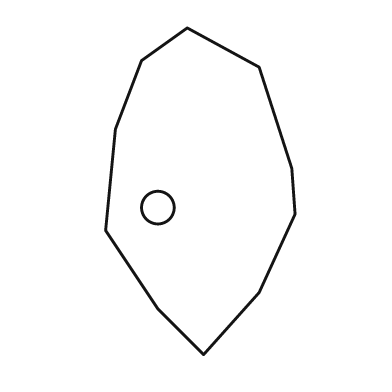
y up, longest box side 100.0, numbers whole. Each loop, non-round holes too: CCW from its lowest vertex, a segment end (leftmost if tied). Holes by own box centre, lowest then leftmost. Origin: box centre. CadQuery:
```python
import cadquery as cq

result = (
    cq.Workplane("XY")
    .moveTo(1.0, -50.0)
    .lineTo(18.0, -31.0)
    .lineTo(29.0, -7.0)
    .lineTo(28.0, 7.0)
    .lineTo(18.0, 38.0)
    .lineTo(-4.0, 50.0)
    .lineTo(-18.0, 40.0)
    .lineTo(-26.0, 19.0)
    .lineTo(-29.0, -12.0)
    .lineTo(-13.0, -36.0)
    .close()
    .moveTo(-13.0, -5.0)
    .circle(5.0)
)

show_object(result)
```